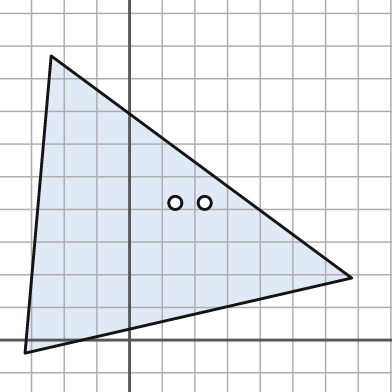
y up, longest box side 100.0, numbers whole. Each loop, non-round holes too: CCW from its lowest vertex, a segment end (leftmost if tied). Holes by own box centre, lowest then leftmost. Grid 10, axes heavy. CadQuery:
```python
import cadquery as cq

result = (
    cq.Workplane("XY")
    .moveTo(-32.0, -4.0)
    .lineTo(68.0, 19.0)
    .lineTo(-24.0, 87.0)
    .close()
    .moveTo(14.0, 42.0)
    .circle(2.0)
    .moveTo(23.0, 42.0)
    .circle(2.0)
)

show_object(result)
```